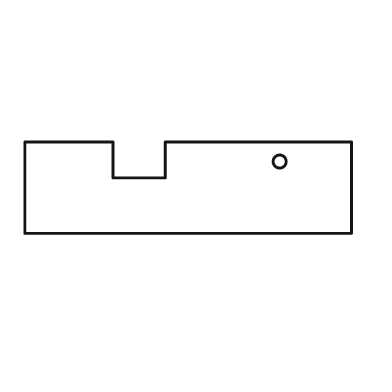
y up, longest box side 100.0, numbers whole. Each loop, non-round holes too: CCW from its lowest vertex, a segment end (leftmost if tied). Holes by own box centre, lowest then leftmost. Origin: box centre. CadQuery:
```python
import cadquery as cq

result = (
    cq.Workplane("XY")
    .moveTo(-50.0, -14.0)
    .lineTo(50.0, -14.0)
    .lineTo(50.0, 14.0)
    .lineTo(-7.0, 14.0)
    .lineTo(-7.0, 3.0)
    .lineTo(-23.0, 3.0)
    .lineTo(-23.0, 14.0)
    .lineTo(-50.0, 14.0)
    .close()
    .moveTo(28.0, 8.0)
    .circle(2.0)
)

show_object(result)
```